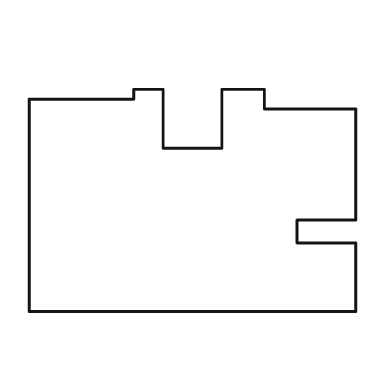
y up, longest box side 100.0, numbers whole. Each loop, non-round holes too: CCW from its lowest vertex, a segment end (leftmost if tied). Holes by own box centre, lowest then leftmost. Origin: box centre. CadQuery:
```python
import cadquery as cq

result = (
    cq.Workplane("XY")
    .moveTo(-50.0, -34.0)
    .lineTo(50.0, -34.0)
    .lineTo(50.0, -13.0)
    .lineTo(32.0, -13.0)
    .lineTo(32.0, -6.0)
    .lineTo(50.0, -6.0)
    .lineTo(50.0, 28.0)
    .lineTo(22.0, 28.0)
    .lineTo(22.0, 34.0)
    .lineTo(9.0, 34.0)
    .lineTo(9.0, 16.0)
    .lineTo(-9.0, 16.0)
    .lineTo(-9.0, 34.0)
    .lineTo(-18.0, 34.0)
    .lineTo(-18.0, 31.0)
    .lineTo(-50.0, 31.0)
    .close()
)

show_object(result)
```